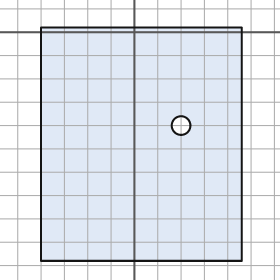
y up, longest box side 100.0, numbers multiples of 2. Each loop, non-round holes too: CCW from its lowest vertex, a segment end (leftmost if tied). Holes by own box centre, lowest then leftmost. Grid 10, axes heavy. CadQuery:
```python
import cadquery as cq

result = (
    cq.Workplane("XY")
    .moveTo(-40.0, -98.0)
    .lineTo(46.0, -98.0)
    .lineTo(46.0, 2.0)
    .lineTo(-40.0, 2.0)
    .close()
    .moveTo(20.0, -40.0)
    .circle(4.0)
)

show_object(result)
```